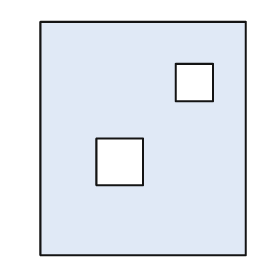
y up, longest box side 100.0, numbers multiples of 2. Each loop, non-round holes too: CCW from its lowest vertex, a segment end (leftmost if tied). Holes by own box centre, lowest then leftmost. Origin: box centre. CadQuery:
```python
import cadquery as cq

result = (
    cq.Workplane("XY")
    .moveTo(-44.0, -50.0)
    .lineTo(44.0, -50.0)
    .lineTo(44.0, 50.0)
    .lineTo(-44.0, 50.0)
    .close()
    .moveTo(-20.0, -20.0)
    .lineTo(0.0, -20.0)
    .lineTo(0.0, 0.0)
    .lineTo(-20.0, 0.0)
    .close()
    .moveTo(14.0, 16.0)
    .lineTo(30.0, 16.0)
    .lineTo(30.0, 32.0)
    .lineTo(14.0, 32.0)
    .close()
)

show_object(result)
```